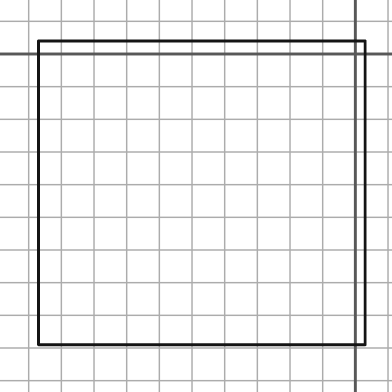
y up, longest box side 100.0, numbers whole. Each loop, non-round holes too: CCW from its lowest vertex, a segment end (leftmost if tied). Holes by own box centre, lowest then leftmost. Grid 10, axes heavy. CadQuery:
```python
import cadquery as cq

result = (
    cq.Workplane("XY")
    .moveTo(-97.0, -89.0)
    .lineTo(3.0, -89.0)
    .lineTo(3.0, 4.0)
    .lineTo(-97.0, 4.0)
    .close()
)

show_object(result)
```